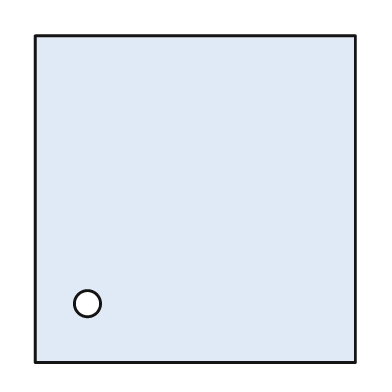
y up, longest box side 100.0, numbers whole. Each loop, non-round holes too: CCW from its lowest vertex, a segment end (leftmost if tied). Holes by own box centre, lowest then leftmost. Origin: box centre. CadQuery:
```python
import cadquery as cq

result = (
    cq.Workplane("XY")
    .moveTo(-49.0, -50.0)
    .lineTo(49.0, -50.0)
    .lineTo(49.0, 50.0)
    .lineTo(-49.0, 50.0)
    .close()
    .moveTo(-33.0, -32.0)
    .circle(4.0)
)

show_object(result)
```